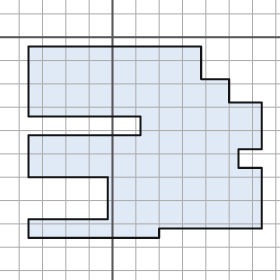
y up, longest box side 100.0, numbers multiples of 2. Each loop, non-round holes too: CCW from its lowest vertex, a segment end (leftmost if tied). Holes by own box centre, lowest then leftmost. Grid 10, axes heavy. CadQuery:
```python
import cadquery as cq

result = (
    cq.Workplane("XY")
    .moveTo(-36.0, -86.0)
    .lineTo(20.0, -86.0)
    .lineTo(20.0, -82.0)
    .lineTo(64.0, -82.0)
    .lineTo(64.0, -56.0)
    .lineTo(54.0, -56.0)
    .lineTo(54.0, -48.0)
    .lineTo(64.0, -48.0)
    .lineTo(64.0, -28.0)
    .lineTo(50.0, -28.0)
    .lineTo(50.0, -18.0)
    .lineTo(38.0, -18.0)
    .lineTo(38.0, -4.0)
    .lineTo(-36.0, -4.0)
    .lineTo(-36.0, -34.0)
    .lineTo(12.0, -34.0)
    .lineTo(12.0, -42.0)
    .lineTo(-36.0, -42.0)
    .lineTo(-36.0, -60.0)
    .lineTo(-2.0, -60.0)
    .lineTo(-2.0, -78.0)
    .lineTo(-36.0, -78.0)
    .close()
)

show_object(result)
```